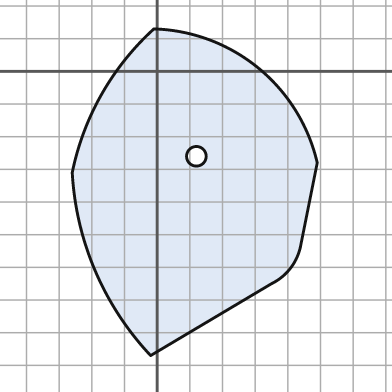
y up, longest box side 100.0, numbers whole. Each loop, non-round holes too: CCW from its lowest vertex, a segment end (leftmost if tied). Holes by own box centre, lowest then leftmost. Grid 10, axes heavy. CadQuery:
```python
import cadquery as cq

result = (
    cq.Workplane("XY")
    .moveTo(-2.0, -87.0)
    .lineTo(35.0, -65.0)
    .threePointArc((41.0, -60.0), (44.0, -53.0))
    .lineTo(49.0, -28.0)
    .threePointArc((31.0, 1.0), (-1.0, 13.0))
    .threePointArc((-17.0, -7.0), (-26.0, -31.0))
    .threePointArc((-19.0, -61.0), (-2.0, -87.0))
    .close()
    .moveTo(12.0, -26.0)
    .circle(3.0)
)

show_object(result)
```